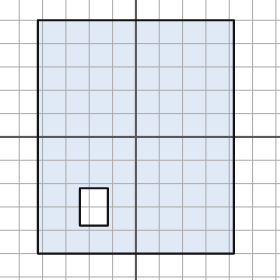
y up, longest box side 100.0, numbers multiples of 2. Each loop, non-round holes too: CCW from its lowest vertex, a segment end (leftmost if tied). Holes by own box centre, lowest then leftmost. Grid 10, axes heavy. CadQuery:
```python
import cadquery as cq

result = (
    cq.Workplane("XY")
    .moveTo(-42.0, -50.0)
    .lineTo(42.0, -50.0)
    .lineTo(42.0, 50.0)
    .lineTo(-42.0, 50.0)
    .close()
    .moveTo(-24.0, -38.0)
    .lineTo(-12.0, -38.0)
    .lineTo(-12.0, -22.0)
    .lineTo(-24.0, -22.0)
    .close()
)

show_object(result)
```